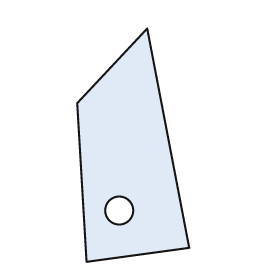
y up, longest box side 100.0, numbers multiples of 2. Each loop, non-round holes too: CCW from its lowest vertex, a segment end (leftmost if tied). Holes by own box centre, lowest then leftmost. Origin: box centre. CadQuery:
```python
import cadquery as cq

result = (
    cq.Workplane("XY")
    .moveTo(-20.0, -50.0)
    .lineTo(24.0, -44.0)
    .lineTo(6.0, 50.0)
    .lineTo(-24.0, 18.0)
    .close()
    .moveTo(-6.0, -28.0)
    .circle(6.0)
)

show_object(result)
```